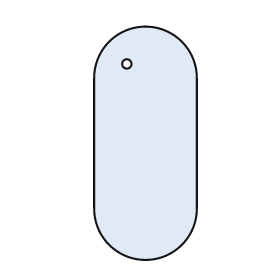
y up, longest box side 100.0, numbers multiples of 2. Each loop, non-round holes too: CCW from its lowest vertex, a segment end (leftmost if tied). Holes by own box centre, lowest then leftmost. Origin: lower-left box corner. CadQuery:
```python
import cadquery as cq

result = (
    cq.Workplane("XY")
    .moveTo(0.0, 22.0)
    .threePointArc((22.0, 0.0), (44.0, 22.0))
    .lineTo(44.0, 78.0)
    .threePointArc((22.0, 100.0), (0.0, 78.0))
    .close()
    .moveTo(14.0, 84.0)
    .circle(2.0)
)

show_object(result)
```